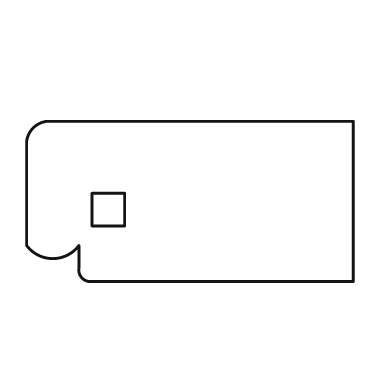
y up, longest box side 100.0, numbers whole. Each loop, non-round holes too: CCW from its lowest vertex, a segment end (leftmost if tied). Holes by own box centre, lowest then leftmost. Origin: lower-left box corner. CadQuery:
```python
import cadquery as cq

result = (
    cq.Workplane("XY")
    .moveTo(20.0, 0.0)
    .lineTo(100.0, 0.0)
    .lineTo(100.0, 49.0)
    .lineTo(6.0, 49.0)
    .threePointArc((2.0, 47.0), (0.0, 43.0))
    .lineTo(0.0, 11.0)
    .threePointArc((8.0, 7.0), (16.0, 11.0))
    .lineTo(16.0, 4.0)
    .threePointArc((17.0, 1.0), (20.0, 0.0))
    .close()
    .moveTo(20.0, 17.0)
    .lineTo(30.0, 17.0)
    .lineTo(30.0, 27.0)
    .lineTo(20.0, 27.0)
    .close()
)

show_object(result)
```